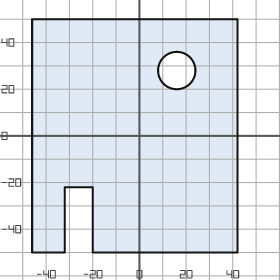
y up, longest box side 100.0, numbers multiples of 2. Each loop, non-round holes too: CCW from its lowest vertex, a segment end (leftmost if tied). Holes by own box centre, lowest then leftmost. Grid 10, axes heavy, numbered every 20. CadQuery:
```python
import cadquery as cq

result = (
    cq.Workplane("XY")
    .moveTo(-46.0, -50.0)
    .lineTo(-32.0, -50.0)
    .lineTo(-32.0, -22.0)
    .lineTo(-20.0, -22.0)
    .lineTo(-20.0, -50.0)
    .lineTo(42.0, -50.0)
    .lineTo(42.0, 50.0)
    .lineTo(-46.0, 50.0)
    .close()
    .moveTo(16.0, 28.0)
    .circle(8.0)
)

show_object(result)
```